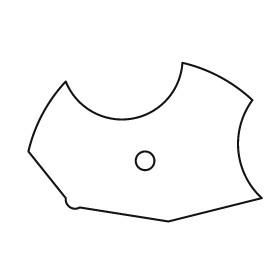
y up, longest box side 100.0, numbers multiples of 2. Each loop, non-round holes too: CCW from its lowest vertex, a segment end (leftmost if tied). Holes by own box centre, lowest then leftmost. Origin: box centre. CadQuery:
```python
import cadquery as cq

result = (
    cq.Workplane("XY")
    .moveTo(10.0, -34.0)
    .lineTo(50.0, -24.0)
    .threePointArc((40.0, -4.0), (46.0, 18.0))
    .threePointArc((32.0, 28.0), (16.0, 34.0))
    .threePointArc((-6.0, 10.0), (-34.0, 26.0))
    .threePointArc((-44.0, 12.0), (-50.0, -4.0))
    .lineTo(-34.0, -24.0)
    .threePointArc((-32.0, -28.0), (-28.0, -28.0))
    .close()
    .moveTo(0.0, -8.0)
    .circle(4.0)
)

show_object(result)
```